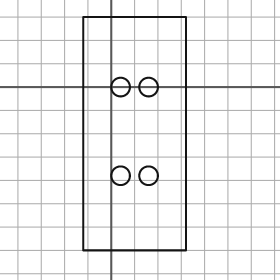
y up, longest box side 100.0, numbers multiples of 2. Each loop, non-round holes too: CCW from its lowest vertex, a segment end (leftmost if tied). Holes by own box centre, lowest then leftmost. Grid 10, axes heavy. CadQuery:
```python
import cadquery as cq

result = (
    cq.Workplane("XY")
    .moveTo(-12.0, -70.0)
    .lineTo(32.0, -70.0)
    .lineTo(32.0, 30.0)
    .lineTo(-12.0, 30.0)
    .close()
    .moveTo(4.0, -38.0)
    .circle(4.0)
    .moveTo(16.0, -38.0)
    .circle(4.0)
    .moveTo(4.0, 0.0)
    .circle(4.0)
    .moveTo(16.0, 0.0)
    .circle(4.0)
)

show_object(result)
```